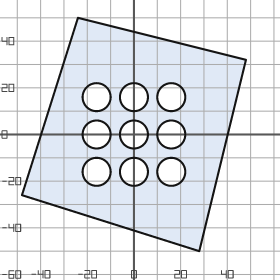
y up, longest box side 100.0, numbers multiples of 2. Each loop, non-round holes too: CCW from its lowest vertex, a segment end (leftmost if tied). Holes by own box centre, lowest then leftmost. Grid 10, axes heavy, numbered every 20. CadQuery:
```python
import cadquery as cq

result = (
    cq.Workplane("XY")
    .moveTo(28.0, -50.0)
    .lineTo(48.0, 32.0)
    .lineTo(-24.0, 50.0)
    .lineTo(-48.0, -26.0)
    .close()
    .moveTo(-16.0, -16.0)
    .circle(6.0)
    .moveTo(0.0, -16.0)
    .circle(6.0)
    .moveTo(16.0, -16.0)
    .circle(6.0)
    .moveTo(-16.0, 0.0)
    .circle(6.0)
    .moveTo(0.0, 0.0)
    .circle(6.0)
    .moveTo(16.0, 0.0)
    .circle(6.0)
    .moveTo(-16.0, 16.0)
    .circle(6.0)
    .moveTo(0.0, 16.0)
    .circle(6.0)
    .moveTo(16.0, 16.0)
    .circle(6.0)
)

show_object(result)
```